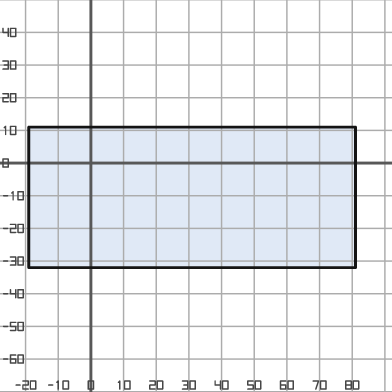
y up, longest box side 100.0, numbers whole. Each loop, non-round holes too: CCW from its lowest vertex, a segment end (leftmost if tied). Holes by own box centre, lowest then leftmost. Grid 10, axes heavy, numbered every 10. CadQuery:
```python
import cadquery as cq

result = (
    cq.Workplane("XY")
    .moveTo(-19.0, -32.0)
    .lineTo(81.0, -32.0)
    .lineTo(81.0, 11.0)
    .lineTo(-19.0, 11.0)
    .close()
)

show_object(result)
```